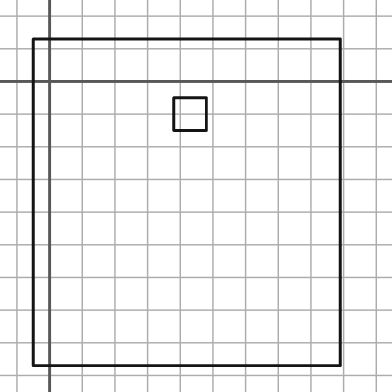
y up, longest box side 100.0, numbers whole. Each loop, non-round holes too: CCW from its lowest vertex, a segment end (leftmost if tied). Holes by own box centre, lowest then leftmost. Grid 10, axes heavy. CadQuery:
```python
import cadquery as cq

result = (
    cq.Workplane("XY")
    .moveTo(-5.0, -87.0)
    .lineTo(89.0, -87.0)
    .lineTo(89.0, 13.0)
    .lineTo(-5.0, 13.0)
    .close()
    .moveTo(38.0, -15.0)
    .lineTo(48.0, -15.0)
    .lineTo(48.0, -5.0)
    .lineTo(38.0, -5.0)
    .close()
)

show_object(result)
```